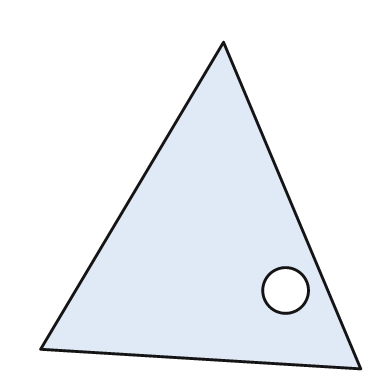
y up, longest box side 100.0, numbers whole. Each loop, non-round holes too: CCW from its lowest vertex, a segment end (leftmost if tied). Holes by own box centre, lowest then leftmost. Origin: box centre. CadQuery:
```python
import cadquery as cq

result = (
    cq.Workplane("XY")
    .moveTo(49.0, -50.0)
    .lineTo(7.0, 50.0)
    .lineTo(-49.0, -44.0)
    .close()
    .moveTo(26.0, -26.0)
    .circle(7.0)
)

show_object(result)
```